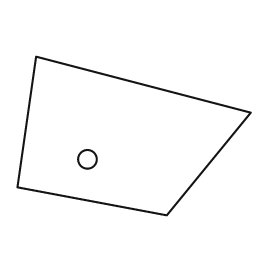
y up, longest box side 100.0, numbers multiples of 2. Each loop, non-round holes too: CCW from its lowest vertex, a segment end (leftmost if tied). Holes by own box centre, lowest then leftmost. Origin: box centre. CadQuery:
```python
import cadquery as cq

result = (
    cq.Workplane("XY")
    .moveTo(14.0, -34.0)
    .lineTo(50.0, 10.0)
    .lineTo(-42.0, 34.0)
    .lineTo(-50.0, -22.0)
    .close()
    .moveTo(-20.0, -10.0)
    .circle(4.0)
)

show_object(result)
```